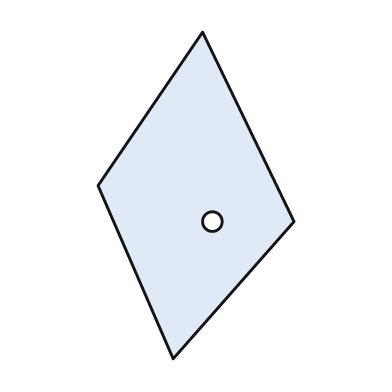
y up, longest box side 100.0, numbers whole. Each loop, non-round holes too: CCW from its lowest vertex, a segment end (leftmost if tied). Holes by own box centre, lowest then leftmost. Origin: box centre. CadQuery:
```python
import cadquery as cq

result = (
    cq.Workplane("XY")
    .moveTo(-7.0, -50.0)
    .lineTo(30.0, -8.0)
    .lineTo(2.0, 50.0)
    .lineTo(-30.0, 3.0)
    .close()
    .moveTo(5.0, -8.0)
    .circle(3.0)
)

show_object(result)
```